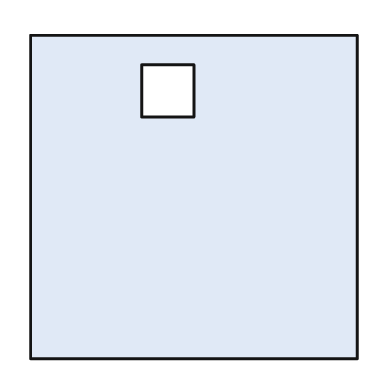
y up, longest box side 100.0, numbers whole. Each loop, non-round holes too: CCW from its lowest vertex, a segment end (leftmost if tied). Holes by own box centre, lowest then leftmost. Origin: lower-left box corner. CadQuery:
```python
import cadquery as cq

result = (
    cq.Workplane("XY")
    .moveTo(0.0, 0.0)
    .lineTo(100.0, 0.0)
    .lineTo(100.0, 99.0)
    .lineTo(0.0, 99.0)
    .close()
    .moveTo(34.0, 74.0)
    .lineTo(50.0, 74.0)
    .lineTo(50.0, 90.0)
    .lineTo(34.0, 90.0)
    .close()
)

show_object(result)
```